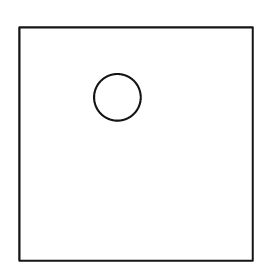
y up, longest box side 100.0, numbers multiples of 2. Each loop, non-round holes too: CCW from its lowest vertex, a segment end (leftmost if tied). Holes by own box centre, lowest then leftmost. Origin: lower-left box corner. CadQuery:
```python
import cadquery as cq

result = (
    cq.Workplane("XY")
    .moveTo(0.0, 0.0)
    .lineTo(100.0, 0.0)
    .lineTo(100.0, 100.0)
    .lineTo(0.0, 100.0)
    .close()
    .moveTo(42.0, 70.0)
    .circle(10.0)
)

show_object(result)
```